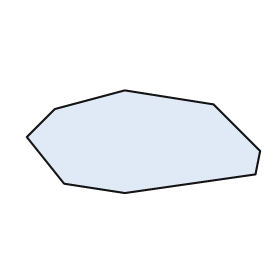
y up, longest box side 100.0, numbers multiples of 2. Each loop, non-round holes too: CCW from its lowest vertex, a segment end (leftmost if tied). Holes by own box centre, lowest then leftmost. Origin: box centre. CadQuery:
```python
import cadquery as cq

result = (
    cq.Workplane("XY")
    .moveTo(-8.0, -22.0)
    .lineTo(48.0, -14.0)
    .lineTo(50.0, -4.0)
    .lineTo(30.0, 16.0)
    .lineTo(-8.0, 22.0)
    .lineTo(-38.0, 14.0)
    .lineTo(-50.0, 2.0)
    .lineTo(-34.0, -18.0)
    .close()
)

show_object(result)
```